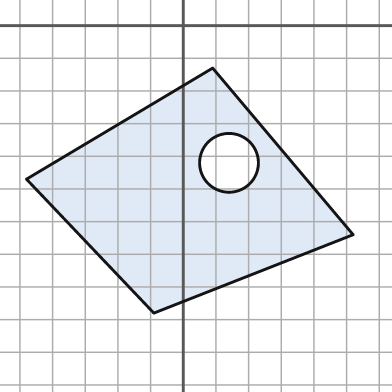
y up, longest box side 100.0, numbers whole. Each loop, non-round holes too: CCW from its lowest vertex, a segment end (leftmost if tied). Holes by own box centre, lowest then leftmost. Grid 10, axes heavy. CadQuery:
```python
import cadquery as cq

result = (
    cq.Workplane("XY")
    .moveTo(-9.0, -88.0)
    .lineTo(52.0, -64.0)
    .lineTo(9.0, -13.0)
    .lineTo(-48.0, -47.0)
    .close()
    .moveTo(14.0, -42.0)
    .circle(9.0)
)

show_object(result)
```